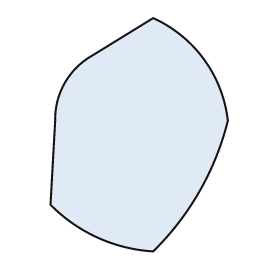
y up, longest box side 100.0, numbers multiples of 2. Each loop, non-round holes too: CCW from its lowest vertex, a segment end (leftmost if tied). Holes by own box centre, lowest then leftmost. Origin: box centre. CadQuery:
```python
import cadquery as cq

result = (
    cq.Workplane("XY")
    .moveTo(6.0, -50.0)
    .threePointArc((26.0, -24.0), (38.0, 6.0))
    .threePointArc((28.0, 32.0), (6.0, 50.0))
    .lineTo(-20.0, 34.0)
    .threePointArc((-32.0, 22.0), (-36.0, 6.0))
    .lineTo(-38.0, -30.0)
    .threePointArc((-18.0, -44.0), (6.0, -50.0))
    .close()
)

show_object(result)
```